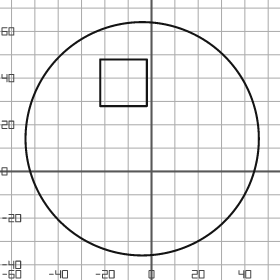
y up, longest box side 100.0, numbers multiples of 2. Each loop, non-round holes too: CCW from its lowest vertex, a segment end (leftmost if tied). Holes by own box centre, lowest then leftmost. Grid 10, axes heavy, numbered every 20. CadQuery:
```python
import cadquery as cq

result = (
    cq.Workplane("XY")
    .moveTo(-4.0, 14.0)
    .circle(50.0)
    .moveTo(-22.0, 28.0)
    .lineTo(-2.0, 28.0)
    .lineTo(-2.0, 48.0)
    .lineTo(-22.0, 48.0)
    .close()
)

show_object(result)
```